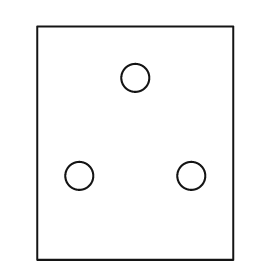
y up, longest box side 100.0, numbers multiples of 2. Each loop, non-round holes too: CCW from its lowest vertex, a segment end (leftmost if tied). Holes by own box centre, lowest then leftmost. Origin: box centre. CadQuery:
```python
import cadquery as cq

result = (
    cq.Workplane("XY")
    .moveTo(-42.0, -50.0)
    .lineTo(42.0, -50.0)
    .lineTo(42.0, 50.0)
    .lineTo(-42.0, 50.0)
    .close()
    .moveTo(-24.0, -14.0)
    .circle(6.0)
    .moveTo(24.0, -14.0)
    .circle(6.0)
    .moveTo(0.0, 28.0)
    .circle(6.0)
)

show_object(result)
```